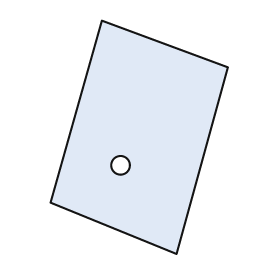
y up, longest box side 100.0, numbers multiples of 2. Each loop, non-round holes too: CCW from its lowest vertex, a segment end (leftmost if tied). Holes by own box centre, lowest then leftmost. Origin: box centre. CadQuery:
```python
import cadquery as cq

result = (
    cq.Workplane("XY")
    .moveTo(16.0, -50.0)
    .lineTo(38.0, 30.0)
    .lineTo(-16.0, 50.0)
    .lineTo(-38.0, -28.0)
    .close()
    .moveTo(-8.0, -12.0)
    .circle(4.0)
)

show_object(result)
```